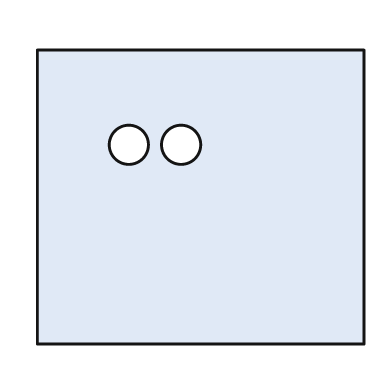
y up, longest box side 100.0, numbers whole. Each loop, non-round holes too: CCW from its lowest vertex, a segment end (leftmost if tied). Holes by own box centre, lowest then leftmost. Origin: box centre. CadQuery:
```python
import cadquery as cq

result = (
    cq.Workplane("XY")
    .moveTo(-50.0, -45.0)
    .lineTo(50.0, -45.0)
    .lineTo(50.0, 45.0)
    .lineTo(-50.0, 45.0)
    .close()
    .moveTo(-22.0, 16.0)
    .circle(6.0)
    .moveTo(-6.0, 16.0)
    .circle(6.0)
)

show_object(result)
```